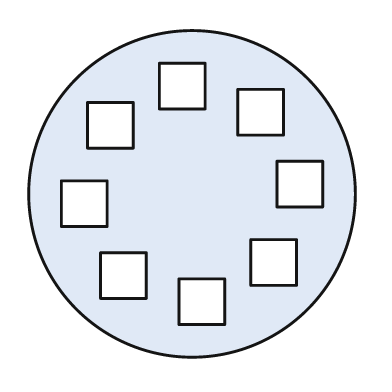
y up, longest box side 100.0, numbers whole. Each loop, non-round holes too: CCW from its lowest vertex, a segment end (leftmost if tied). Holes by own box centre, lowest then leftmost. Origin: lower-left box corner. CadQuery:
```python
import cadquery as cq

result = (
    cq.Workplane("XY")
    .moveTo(50.0, 50.0)
    .circle(50.0)
    .moveTo(46.0, 10.0)
    .lineTo(60.0, 10.0)
    .lineTo(60.0, 24.0)
    .lineTo(46.0, 24.0)
    .close()
    .moveTo(22.0, 18.0)
    .lineTo(36.0, 18.0)
    .lineTo(36.0, 32.0)
    .lineTo(22.0, 32.0)
    .close()
    .moveTo(68.0, 22.0)
    .lineTo(82.0, 22.0)
    .lineTo(82.0, 36.0)
    .lineTo(68.0, 36.0)
    .close()
    .moveTo(10.0, 40.0)
    .lineTo(24.0, 40.0)
    .lineTo(24.0, 54.0)
    .lineTo(10.0, 54.0)
    .close()
    .moveTo(76.0, 46.0)
    .lineTo(90.0, 46.0)
    .lineTo(90.0, 60.0)
    .lineTo(76.0, 60.0)
    .close()
    .moveTo(18.0, 64.0)
    .lineTo(32.0, 64.0)
    .lineTo(32.0, 78.0)
    .lineTo(18.0, 78.0)
    .close()
    .moveTo(64.0, 68.0)
    .lineTo(78.0, 68.0)
    .lineTo(78.0, 82.0)
    .lineTo(64.0, 82.0)
    .close()
    .moveTo(40.0, 76.0)
    .lineTo(54.0, 76.0)
    .lineTo(54.0, 90.0)
    .lineTo(40.0, 90.0)
    .close()
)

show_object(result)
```